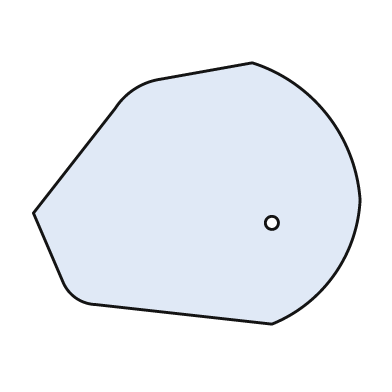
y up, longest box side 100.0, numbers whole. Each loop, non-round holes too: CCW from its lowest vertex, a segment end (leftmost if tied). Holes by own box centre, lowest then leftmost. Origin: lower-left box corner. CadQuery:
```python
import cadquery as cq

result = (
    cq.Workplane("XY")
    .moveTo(73.0, 0.0)
    .threePointArc((92.0, 15.0), (100.0, 38.0))
    .threePointArc((90.0, 64.0), (67.0, 80.0))
    .lineTo(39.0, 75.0)
    .threePointArc((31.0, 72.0), (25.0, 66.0))
    .lineTo(0.0, 34.0)
    .lineTo(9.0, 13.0)
    .threePointArc((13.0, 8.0), (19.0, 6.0))
    .close()
    .moveTo(73.0, 31.0)
    .circle(2.0)
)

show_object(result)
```